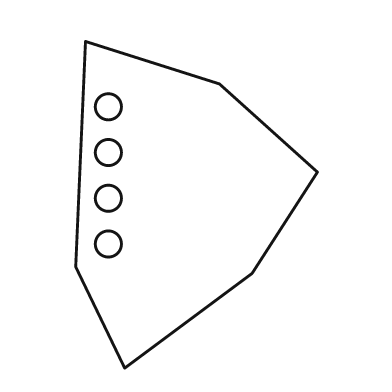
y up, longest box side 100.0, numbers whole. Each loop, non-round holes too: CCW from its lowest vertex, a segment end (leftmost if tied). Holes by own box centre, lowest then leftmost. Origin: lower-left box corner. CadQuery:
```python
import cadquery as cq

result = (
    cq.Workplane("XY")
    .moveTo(15.0, 0.0)
    .lineTo(54.0, 29.0)
    .lineTo(74.0, 60.0)
    .lineTo(44.0, 87.0)
    .lineTo(3.0, 100.0)
    .lineTo(0.0, 31.0)
    .close()
    .moveTo(10.0, 38.0)
    .circle(4.0)
    .moveTo(10.0, 52.0)
    .circle(4.0)
    .moveTo(10.0, 66.0)
    .circle(4.0)
    .moveTo(10.0, 80.0)
    .circle(4.0)
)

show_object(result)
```